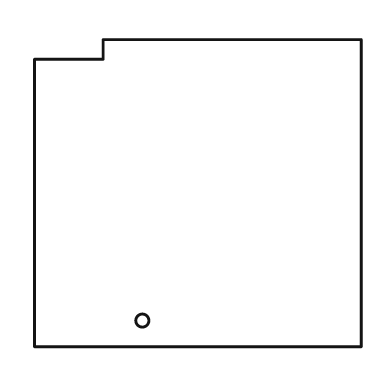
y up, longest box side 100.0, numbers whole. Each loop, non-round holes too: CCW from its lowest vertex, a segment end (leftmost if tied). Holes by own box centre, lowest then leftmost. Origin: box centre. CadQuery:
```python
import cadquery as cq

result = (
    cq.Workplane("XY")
    .moveTo(-50.0, -47.0)
    .lineTo(50.0, -47.0)
    .lineTo(50.0, 47.0)
    .lineTo(-29.0, 47.0)
    .lineTo(-29.0, 41.0)
    .lineTo(-50.0, 41.0)
    .close()
    .moveTo(-17.0, -39.0)
    .circle(2.0)
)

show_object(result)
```